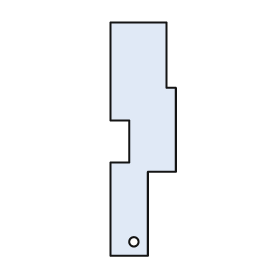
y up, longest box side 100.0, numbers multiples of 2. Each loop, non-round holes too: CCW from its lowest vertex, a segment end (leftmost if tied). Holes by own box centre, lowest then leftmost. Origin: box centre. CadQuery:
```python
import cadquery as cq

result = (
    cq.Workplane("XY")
    .moveTo(-14.0, -50.0)
    .lineTo(2.0, -50.0)
    .lineTo(2.0, -14.0)
    .lineTo(14.0, -14.0)
    .lineTo(14.0, 22.0)
    .lineTo(10.0, 22.0)
    .lineTo(10.0, 50.0)
    .lineTo(-14.0, 50.0)
    .lineTo(-14.0, 8.0)
    .lineTo(-6.0, 8.0)
    .lineTo(-6.0, -10.0)
    .lineTo(-14.0, -10.0)
    .close()
    .moveTo(-4.0, -44.0)
    .circle(2.0)
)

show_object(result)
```